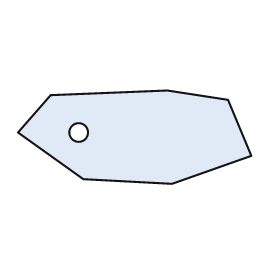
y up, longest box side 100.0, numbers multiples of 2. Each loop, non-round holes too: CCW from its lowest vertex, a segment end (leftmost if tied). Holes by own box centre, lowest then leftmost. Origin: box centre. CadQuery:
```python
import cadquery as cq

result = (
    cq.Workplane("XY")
    .moveTo(16.0, -20.0)
    .lineTo(50.0, -8.0)
    .lineTo(40.0, 16.0)
    .lineTo(14.0, 20.0)
    .lineTo(-36.0, 18.0)
    .lineTo(-50.0, 2.0)
    .lineTo(-22.0, -18.0)
    .close()
    .moveTo(-24.0, 2.0)
    .circle(4.0)
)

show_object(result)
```